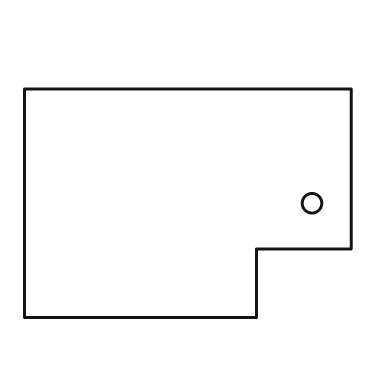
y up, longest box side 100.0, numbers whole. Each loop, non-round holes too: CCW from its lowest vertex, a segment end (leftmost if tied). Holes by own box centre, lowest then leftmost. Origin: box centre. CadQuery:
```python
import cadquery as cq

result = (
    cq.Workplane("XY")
    .moveTo(-50.0, -35.0)
    .lineTo(21.0, -35.0)
    .lineTo(21.0, -14.0)
    .lineTo(50.0, -14.0)
    .lineTo(50.0, 35.0)
    .lineTo(-50.0, 35.0)
    .close()
    .moveTo(38.0, 0.0)
    .circle(3.0)
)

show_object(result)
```